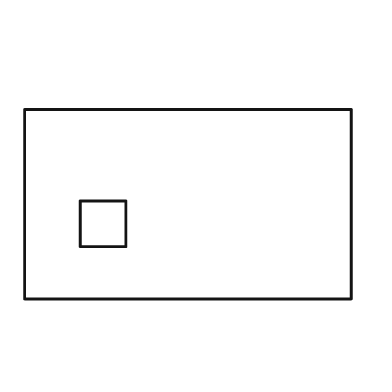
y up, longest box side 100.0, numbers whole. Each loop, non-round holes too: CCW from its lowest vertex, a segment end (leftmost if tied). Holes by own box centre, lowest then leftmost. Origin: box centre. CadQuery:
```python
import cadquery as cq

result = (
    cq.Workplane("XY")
    .moveTo(-50.0, -29.0)
    .lineTo(50.0, -29.0)
    .lineTo(50.0, 29.0)
    .lineTo(-50.0, 29.0)
    .close()
    .moveTo(-33.0, -13.0)
    .lineTo(-19.0, -13.0)
    .lineTo(-19.0, 1.0)
    .lineTo(-33.0, 1.0)
    .close()
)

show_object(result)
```